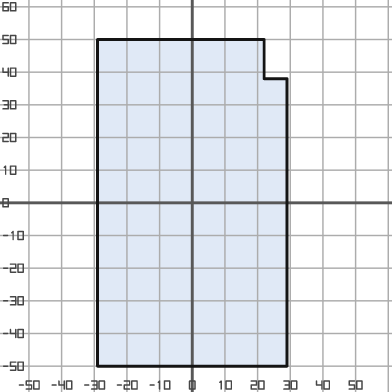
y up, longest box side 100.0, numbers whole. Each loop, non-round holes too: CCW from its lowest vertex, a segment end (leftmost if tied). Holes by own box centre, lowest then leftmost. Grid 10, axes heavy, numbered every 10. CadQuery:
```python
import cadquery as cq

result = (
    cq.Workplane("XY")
    .moveTo(-29.0, -50.0)
    .lineTo(29.0, -50.0)
    .lineTo(29.0, 38.0)
    .lineTo(22.0, 38.0)
    .lineTo(22.0, 50.0)
    .lineTo(-29.0, 50.0)
    .close()
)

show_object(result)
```